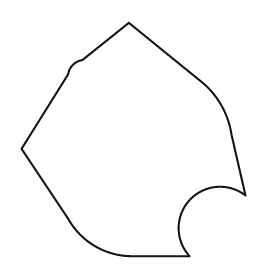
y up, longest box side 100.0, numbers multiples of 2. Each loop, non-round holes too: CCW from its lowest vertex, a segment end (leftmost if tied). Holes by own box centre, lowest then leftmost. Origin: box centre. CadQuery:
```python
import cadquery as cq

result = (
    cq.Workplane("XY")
    .moveTo(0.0, -50.0)
    .lineTo(24.0, -50.0)
    .threePointArc((24.0, -26.0), (48.0, -24.0))
    .lineTo(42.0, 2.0)
    .threePointArc((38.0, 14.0), (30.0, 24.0))
    .lineTo(-2.0, 50.0)
    .lineTo(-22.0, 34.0)
    .threePointArc((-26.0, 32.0), (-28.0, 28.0))
    .lineTo(-48.0, -4.0)
    .lineTo(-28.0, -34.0)
    .threePointArc((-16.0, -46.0), (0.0, -50.0))
    .close()
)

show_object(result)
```